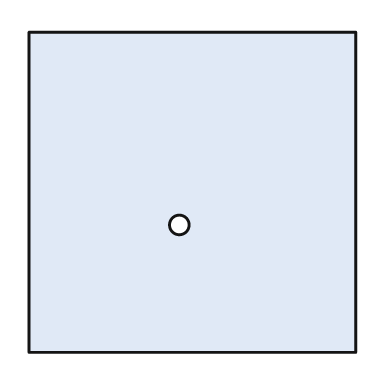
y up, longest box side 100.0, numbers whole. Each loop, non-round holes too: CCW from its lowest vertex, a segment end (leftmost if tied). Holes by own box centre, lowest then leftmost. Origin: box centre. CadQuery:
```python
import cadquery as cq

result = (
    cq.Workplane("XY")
    .moveTo(-50.0, -49.0)
    .lineTo(50.0, -49.0)
    .lineTo(50.0, 49.0)
    .lineTo(-50.0, 49.0)
    .close()
    .moveTo(-4.0, -10.0)
    .circle(3.0)
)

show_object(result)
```